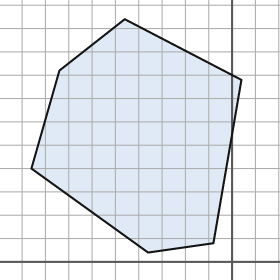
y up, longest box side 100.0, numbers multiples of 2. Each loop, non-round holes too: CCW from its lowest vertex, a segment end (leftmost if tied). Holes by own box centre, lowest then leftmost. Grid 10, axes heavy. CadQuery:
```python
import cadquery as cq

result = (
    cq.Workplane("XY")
    .moveTo(-36.0, 4.0)
    .lineTo(-8.0, 8.0)
    .lineTo(4.0, 78.0)
    .lineTo(-46.0, 104.0)
    .lineTo(-74.0, 82.0)
    .lineTo(-86.0, 40.0)
    .close()
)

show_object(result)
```